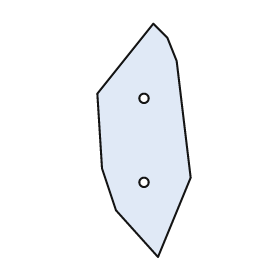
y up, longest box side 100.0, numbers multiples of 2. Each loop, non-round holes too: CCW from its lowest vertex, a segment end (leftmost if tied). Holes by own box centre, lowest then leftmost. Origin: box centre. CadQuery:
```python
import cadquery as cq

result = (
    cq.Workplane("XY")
    .moveTo(6.0, -50.0)
    .lineTo(20.0, -16.0)
    .lineTo(14.0, 34.0)
    .lineTo(10.0, 44.0)
    .lineTo(4.0, 50.0)
    .lineTo(-20.0, 20.0)
    .lineTo(-18.0, -12.0)
    .lineTo(-12.0, -30.0)
    .close()
    .moveTo(0.0, -18.0)
    .circle(2.0)
    .moveTo(0.0, 18.0)
    .circle(2.0)
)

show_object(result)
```